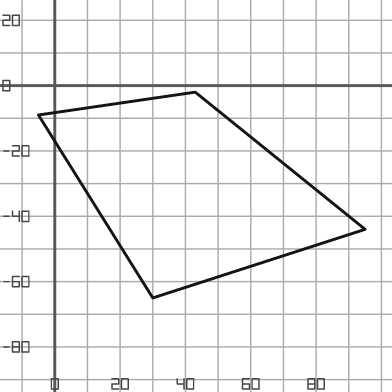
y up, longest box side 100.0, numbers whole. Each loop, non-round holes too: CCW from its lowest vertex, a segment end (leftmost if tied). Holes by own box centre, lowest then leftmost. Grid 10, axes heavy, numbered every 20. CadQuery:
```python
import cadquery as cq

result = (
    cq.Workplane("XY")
    .moveTo(30.0, -65.0)
    .lineTo(95.0, -44.0)
    .lineTo(43.0, -2.0)
    .lineTo(-5.0, -9.0)
    .close()
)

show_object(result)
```